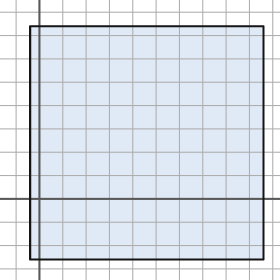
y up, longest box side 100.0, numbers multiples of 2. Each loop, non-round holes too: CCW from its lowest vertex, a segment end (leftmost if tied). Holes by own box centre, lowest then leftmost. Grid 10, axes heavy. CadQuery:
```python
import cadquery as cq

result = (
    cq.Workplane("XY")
    .moveTo(-4.0, -26.0)
    .lineTo(96.0, -26.0)
    .lineTo(96.0, 74.0)
    .lineTo(-4.0, 74.0)
    .close()
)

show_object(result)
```